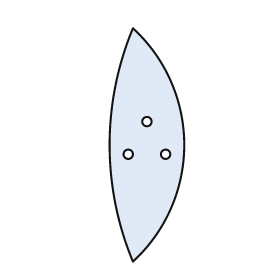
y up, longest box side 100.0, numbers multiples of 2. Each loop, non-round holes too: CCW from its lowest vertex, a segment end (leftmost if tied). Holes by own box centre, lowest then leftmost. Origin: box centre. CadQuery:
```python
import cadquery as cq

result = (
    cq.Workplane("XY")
    .moveTo(-6.0, -50.0)
    .threePointArc((16.0, 0.0), (-6.0, 50.0))
    .threePointArc((-16.0, 0.0), (-6.0, -50.0))
    .close()
    .moveTo(-8.0, -4.0)
    .circle(2.0)
    .moveTo(8.0, -4.0)
    .circle(2.0)
    .moveTo(0.0, 10.0)
    .circle(2.0)
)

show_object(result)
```